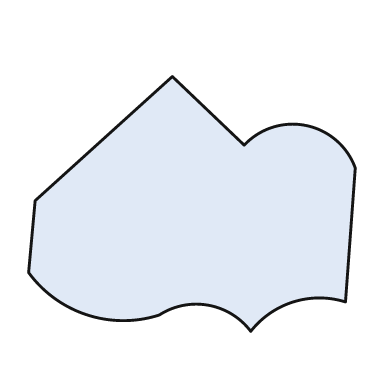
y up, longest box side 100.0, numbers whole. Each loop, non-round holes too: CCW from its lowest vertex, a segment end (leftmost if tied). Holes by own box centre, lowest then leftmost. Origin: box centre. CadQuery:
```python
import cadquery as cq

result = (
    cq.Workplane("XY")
    .moveTo(18.0, -39.0)
    .threePointArc((31.0, -30.0), (47.0, -30.0))
    .lineTo(50.0, 11.0)
    .threePointArc((35.0, 24.0), (16.0, 18.0))
    .lineTo(-6.0, 39.0)
    .lineTo(-48.0, 1.0)
    .lineTo(-50.0, -21.0)
    .threePointArc((-32.0, -34.0), (-10.0, -34.0))
    .threePointArc((5.0, -31.0), (18.0, -39.0))
    .close()
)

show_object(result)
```